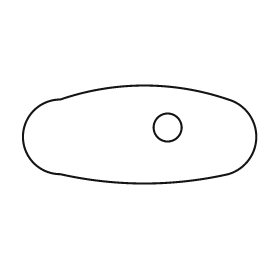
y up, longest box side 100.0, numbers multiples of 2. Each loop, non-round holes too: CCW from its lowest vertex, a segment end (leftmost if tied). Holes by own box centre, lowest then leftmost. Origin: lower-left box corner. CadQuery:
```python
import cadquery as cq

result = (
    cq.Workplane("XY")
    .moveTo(16.0, 4.0)
    .threePointArc((52.0, 0.0), (88.0, 4.0))
    .threePointArc((100.0, 20.0), (88.0, 36.0))
    .threePointArc((52.0, 42.0), (16.0, 36.0))
    .threePointArc((0.0, 20.0), (16.0, 4.0))
    .close()
    .moveTo(62.0, 24.0)
    .circle(6.0)
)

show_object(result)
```